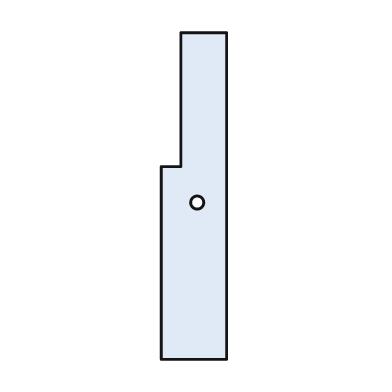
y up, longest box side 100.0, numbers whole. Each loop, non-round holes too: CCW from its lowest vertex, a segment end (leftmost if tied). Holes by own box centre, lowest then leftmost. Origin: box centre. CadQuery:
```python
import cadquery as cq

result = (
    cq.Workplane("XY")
    .moveTo(-10.0, -50.0)
    .lineTo(10.0, -50.0)
    .lineTo(10.0, 50.0)
    .lineTo(-4.0, 50.0)
    .lineTo(-4.0, 9.0)
    .lineTo(-10.0, 9.0)
    .close()
    .moveTo(1.0, -2.0)
    .circle(2.0)
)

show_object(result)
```